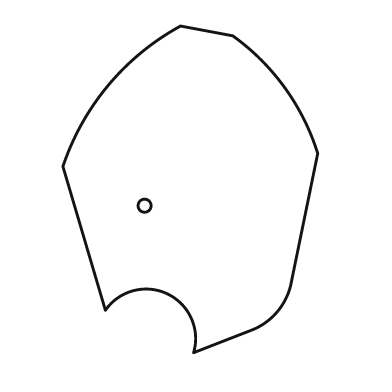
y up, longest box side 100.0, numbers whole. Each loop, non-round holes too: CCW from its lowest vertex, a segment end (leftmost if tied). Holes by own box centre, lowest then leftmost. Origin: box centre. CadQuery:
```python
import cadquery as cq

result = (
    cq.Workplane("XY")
    .moveTo(1.0, -50.0)
    .lineTo(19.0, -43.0)
    .threePointArc((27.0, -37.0), (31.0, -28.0))
    .lineTo(39.0, 11.0)
    .threePointArc((29.0, 31.0), (13.0, 47.0))
    .lineTo(-3.0, 50.0)
    .threePointArc((-25.0, 32.0), (-39.0, 7.0))
    .lineTo(-26.0, -37.0)
    .threePointArc((-7.0, -32.0), (1.0, -50.0))
    .close()
    .moveTo(-14.0, -5.0)
    .circle(2.0)
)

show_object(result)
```